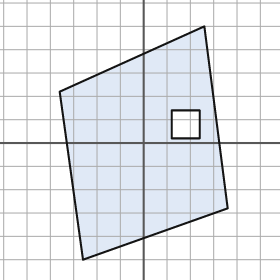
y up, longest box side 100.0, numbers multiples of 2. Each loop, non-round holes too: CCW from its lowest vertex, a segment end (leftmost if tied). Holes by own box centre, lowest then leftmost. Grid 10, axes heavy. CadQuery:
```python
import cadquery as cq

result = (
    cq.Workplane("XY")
    .moveTo(-26.0, -50.0)
    .lineTo(36.0, -28.0)
    .lineTo(26.0, 50.0)
    .lineTo(-36.0, 22.0)
    .close()
    .moveTo(12.0, 2.0)
    .lineTo(24.0, 2.0)
    .lineTo(24.0, 14.0)
    .lineTo(12.0, 14.0)
    .close()
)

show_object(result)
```